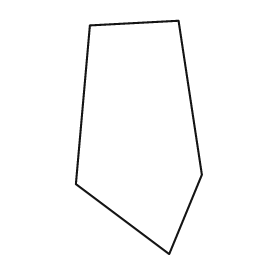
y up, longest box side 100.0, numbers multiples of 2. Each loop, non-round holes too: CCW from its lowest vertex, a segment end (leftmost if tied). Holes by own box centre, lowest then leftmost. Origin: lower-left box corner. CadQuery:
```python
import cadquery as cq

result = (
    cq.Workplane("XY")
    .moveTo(40.0, 0.0)
    .lineTo(54.0, 34.0)
    .lineTo(44.0, 100.0)
    .lineTo(6.0, 98.0)
    .lineTo(0.0, 30.0)
    .close()
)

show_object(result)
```